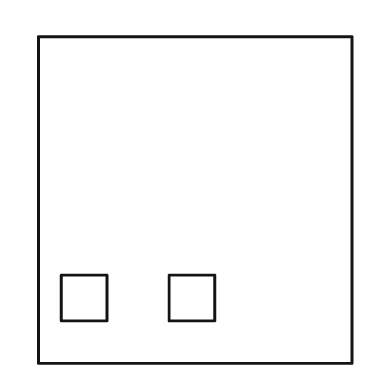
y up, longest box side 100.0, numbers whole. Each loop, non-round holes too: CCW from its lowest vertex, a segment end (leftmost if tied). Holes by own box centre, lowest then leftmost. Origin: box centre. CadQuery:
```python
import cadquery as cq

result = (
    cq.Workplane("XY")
    .moveTo(-48.0, -50.0)
    .lineTo(48.0, -50.0)
    .lineTo(48.0, 50.0)
    .lineTo(-48.0, 50.0)
    .close()
    .moveTo(-41.0, -37.0)
    .lineTo(-27.0, -37.0)
    .lineTo(-27.0, -23.0)
    .lineTo(-41.0, -23.0)
    .close()
    .moveTo(-8.0, -37.0)
    .lineTo(6.0, -37.0)
    .lineTo(6.0, -23.0)
    .lineTo(-8.0, -23.0)
    .close()
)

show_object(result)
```